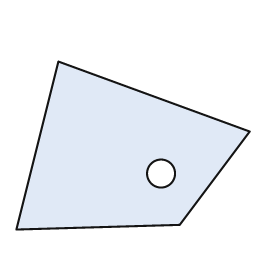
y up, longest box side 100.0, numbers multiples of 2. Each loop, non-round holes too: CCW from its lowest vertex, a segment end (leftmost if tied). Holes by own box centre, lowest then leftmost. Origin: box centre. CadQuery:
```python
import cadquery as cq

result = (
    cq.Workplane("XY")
    .moveTo(-50.0, -36.0)
    .lineTo(20.0, -34.0)
    .lineTo(50.0, 6.0)
    .lineTo(-32.0, 36.0)
    .close()
    .moveTo(12.0, -12.0)
    .circle(6.0)
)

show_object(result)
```